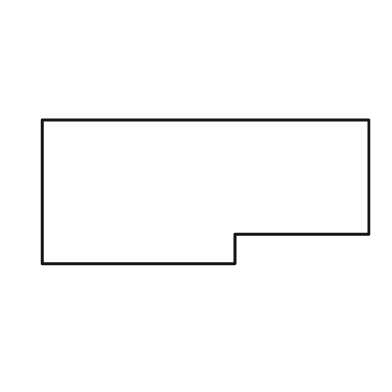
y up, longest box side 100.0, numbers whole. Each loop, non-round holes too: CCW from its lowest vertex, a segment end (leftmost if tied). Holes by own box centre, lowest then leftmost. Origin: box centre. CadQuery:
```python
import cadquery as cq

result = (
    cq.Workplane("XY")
    .moveTo(-50.0, -22.0)
    .lineTo(9.0, -22.0)
    .lineTo(9.0, -13.0)
    .lineTo(50.0, -13.0)
    .lineTo(50.0, 22.0)
    .lineTo(-50.0, 22.0)
    .close()
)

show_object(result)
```